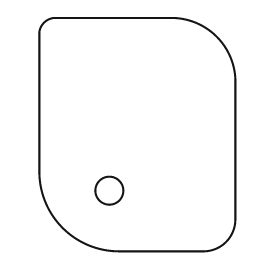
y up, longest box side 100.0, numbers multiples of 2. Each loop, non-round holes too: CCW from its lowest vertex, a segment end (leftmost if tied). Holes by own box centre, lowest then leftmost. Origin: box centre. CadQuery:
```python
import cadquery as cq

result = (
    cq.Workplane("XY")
    .moveTo(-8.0, -50.0)
    .lineTo(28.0, -50.0)
    .threePointArc((38.0, -46.0), (42.0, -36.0))
    .lineTo(42.0, 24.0)
    .threePointArc((34.0, 42.0), (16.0, 50.0))
    .lineTo(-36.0, 50.0)
    .threePointArc((-40.0, 48.0), (-42.0, 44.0))
    .lineTo(-42.0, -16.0)
    .threePointArc((-32.0, -40.0), (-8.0, -50.0))
    .close()
    .moveTo(-12.0, -24.0)
    .circle(6.0)
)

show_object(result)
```